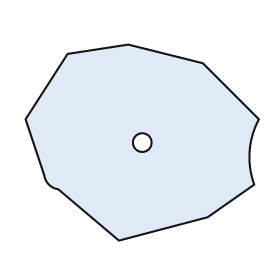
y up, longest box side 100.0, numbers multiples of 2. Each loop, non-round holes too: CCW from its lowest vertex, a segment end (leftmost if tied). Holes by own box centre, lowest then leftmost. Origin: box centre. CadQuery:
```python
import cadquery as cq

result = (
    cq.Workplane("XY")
    .moveTo(-10.0, -42.0)
    .lineTo(28.0, -32.0)
    .lineTo(48.0, -18.0)
    .threePointArc((46.0, -4.0), (50.0, 10.0))
    .lineTo(26.0, 34.0)
    .lineTo(-6.0, 42.0)
    .lineTo(-32.0, 38.0)
    .lineTo(-50.0, 10.0)
    .lineTo(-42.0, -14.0)
    .threePointArc((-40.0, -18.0), (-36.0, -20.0))
    .close()
    .moveTo(0.0, 0.0)
    .circle(4.0)
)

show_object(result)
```